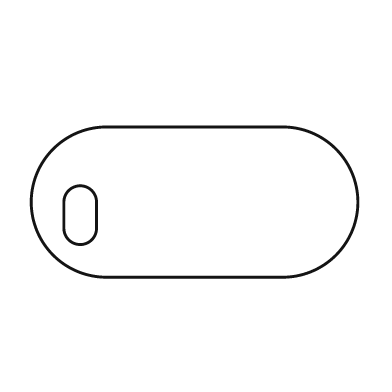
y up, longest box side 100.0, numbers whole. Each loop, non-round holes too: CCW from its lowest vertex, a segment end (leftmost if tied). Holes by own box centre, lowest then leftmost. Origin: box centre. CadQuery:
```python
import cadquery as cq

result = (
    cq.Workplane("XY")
    .moveTo(-27.0, -23.0)
    .lineTo(27.0, -23.0)
    .threePointArc((50.0, 0.0), (27.0, 23.0))
    .lineTo(-27.0, 23.0)
    .threePointArc((-50.0, 0.0), (-27.0, -23.0))
    .close()
    .moveTo(-40.0, -8.0)
    .threePointArc((-35.0, -13.0), (-30.0, -8.0))
    .lineTo(-30.0, 0.0)
    .threePointArc((-35.0, 5.0), (-40.0, 0.0))
    .close()
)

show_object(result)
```